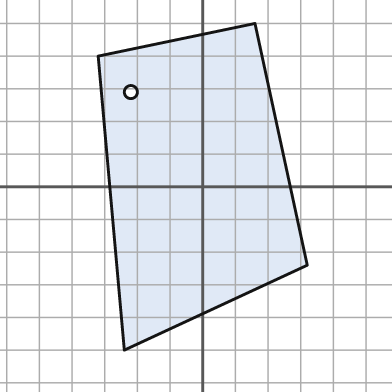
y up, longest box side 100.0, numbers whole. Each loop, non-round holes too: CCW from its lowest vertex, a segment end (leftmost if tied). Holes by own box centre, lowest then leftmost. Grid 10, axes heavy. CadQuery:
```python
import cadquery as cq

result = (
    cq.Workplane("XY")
    .moveTo(-24.0, -50.0)
    .lineTo(32.0, -24.0)
    .lineTo(16.0, 50.0)
    .lineTo(-32.0, 40.0)
    .close()
    .moveTo(-22.0, 29.0)
    .circle(2.0)
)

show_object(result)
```